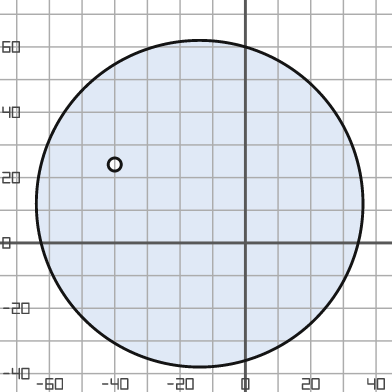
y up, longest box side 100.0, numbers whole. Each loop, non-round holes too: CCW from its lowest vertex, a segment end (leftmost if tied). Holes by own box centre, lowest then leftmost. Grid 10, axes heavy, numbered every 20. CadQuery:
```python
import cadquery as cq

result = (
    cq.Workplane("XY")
    .moveTo(-14.0, 12.0)
    .circle(50.0)
    .moveTo(-40.0, 24.0)
    .circle(2.0)
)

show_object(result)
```